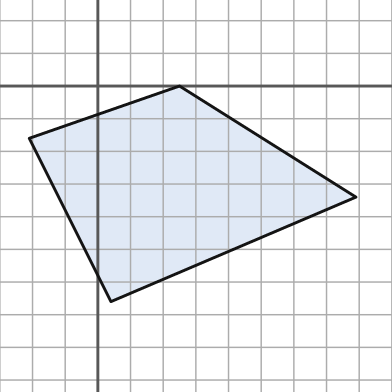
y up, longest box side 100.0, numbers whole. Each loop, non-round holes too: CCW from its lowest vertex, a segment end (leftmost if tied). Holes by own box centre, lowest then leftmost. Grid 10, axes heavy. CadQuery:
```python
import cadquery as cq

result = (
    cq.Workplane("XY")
    .moveTo(4.0, -66.0)
    .lineTo(79.0, -34.0)
    .lineTo(25.0, 0.0)
    .lineTo(-21.0, -16.0)
    .close()
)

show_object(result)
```